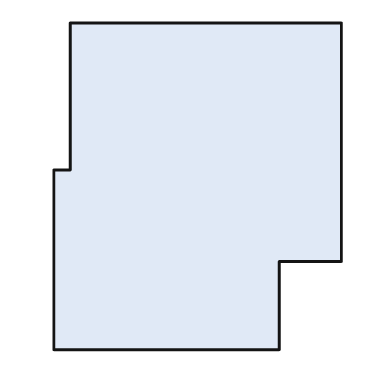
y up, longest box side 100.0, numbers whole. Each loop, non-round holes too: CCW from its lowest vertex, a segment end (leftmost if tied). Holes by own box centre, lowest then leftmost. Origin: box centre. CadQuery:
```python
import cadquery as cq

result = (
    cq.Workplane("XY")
    .moveTo(-44.0, -50.0)
    .lineTo(25.0, -50.0)
    .lineTo(25.0, -23.0)
    .lineTo(44.0, -23.0)
    .lineTo(44.0, 50.0)
    .lineTo(-39.0, 50.0)
    .lineTo(-39.0, 5.0)
    .lineTo(-44.0, 5.0)
    .close()
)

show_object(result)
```